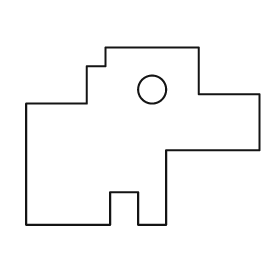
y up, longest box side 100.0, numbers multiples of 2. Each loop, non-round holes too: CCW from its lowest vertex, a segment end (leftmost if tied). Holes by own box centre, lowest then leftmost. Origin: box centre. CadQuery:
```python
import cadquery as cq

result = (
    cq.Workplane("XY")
    .moveTo(-50.0, -38.0)
    .lineTo(-14.0, -38.0)
    .lineTo(-14.0, -24.0)
    .lineTo(-2.0, -24.0)
    .lineTo(-2.0, -38.0)
    .lineTo(10.0, -38.0)
    .lineTo(10.0, -6.0)
    .lineTo(50.0, -6.0)
    .lineTo(50.0, 18.0)
    .lineTo(24.0, 18.0)
    .lineTo(24.0, 38.0)
    .lineTo(-16.0, 38.0)
    .lineTo(-16.0, 30.0)
    .lineTo(-24.0, 30.0)
    .lineTo(-24.0, 14.0)
    .lineTo(-50.0, 14.0)
    .close()
    .moveTo(4.0, 20.0)
    .circle(6.0)
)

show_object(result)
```